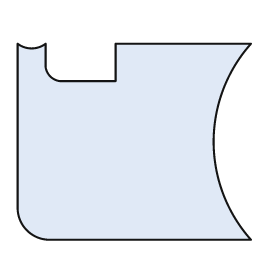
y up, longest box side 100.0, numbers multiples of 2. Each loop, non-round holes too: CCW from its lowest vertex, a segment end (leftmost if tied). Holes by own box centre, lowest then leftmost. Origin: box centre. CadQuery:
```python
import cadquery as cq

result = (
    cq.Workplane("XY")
    .moveTo(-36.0, -42.0)
    .lineTo(50.0, -42.0)
    .threePointArc((34.0, 0.0), (50.0, 42.0))
    .lineTo(-8.0, 42.0)
    .lineTo(-8.0, 26.0)
    .lineTo(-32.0, 26.0)
    .threePointArc((-36.0, 28.0), (-38.0, 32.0))
    .lineTo(-38.0, 42.0)
    .threePointArc((-44.0, 40.0), (-50.0, 42.0))
    .lineTo(-50.0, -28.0)
    .threePointArc((-46.0, -38.0), (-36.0, -42.0))
    .close()
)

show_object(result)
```